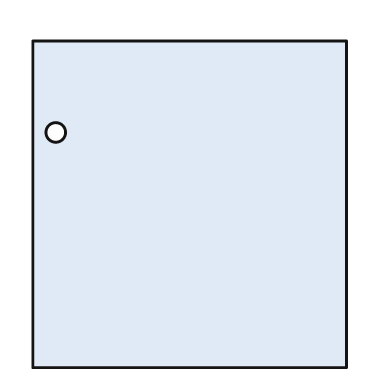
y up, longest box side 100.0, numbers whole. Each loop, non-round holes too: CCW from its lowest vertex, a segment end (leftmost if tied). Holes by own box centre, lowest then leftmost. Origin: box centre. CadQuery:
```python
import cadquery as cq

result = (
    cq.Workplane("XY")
    .moveTo(-48.0, -50.0)
    .lineTo(48.0, -50.0)
    .lineTo(48.0, 50.0)
    .lineTo(-48.0, 50.0)
    .close()
    .moveTo(-41.0, 22.0)
    .circle(3.0)
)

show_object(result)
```